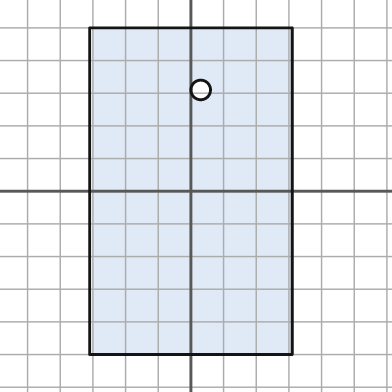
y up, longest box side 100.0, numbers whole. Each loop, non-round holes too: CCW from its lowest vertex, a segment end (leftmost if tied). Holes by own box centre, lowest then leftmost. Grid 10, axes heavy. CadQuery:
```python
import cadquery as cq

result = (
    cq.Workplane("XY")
    .moveTo(-31.0, -50.0)
    .lineTo(31.0, -50.0)
    .lineTo(31.0, 50.0)
    .lineTo(-31.0, 50.0)
    .close()
    .moveTo(3.0, 31.0)
    .circle(3.0)
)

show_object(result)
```